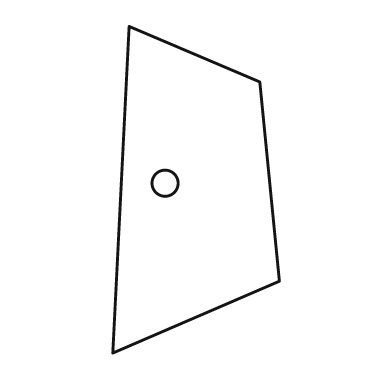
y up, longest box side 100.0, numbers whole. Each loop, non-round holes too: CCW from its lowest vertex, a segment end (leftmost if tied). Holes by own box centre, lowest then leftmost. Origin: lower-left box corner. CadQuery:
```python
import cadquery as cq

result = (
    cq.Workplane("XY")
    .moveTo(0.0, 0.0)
    .lineTo(51.0, 22.0)
    .lineTo(45.0, 83.0)
    .lineTo(5.0, 100.0)
    .close()
    .moveTo(16.0, 52.0)
    .circle(4.0)
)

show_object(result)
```